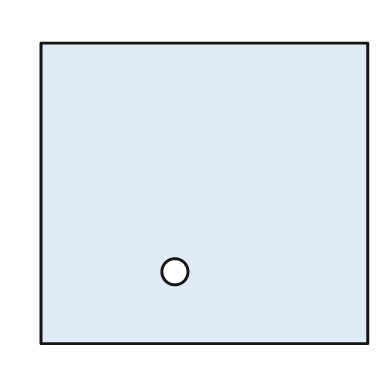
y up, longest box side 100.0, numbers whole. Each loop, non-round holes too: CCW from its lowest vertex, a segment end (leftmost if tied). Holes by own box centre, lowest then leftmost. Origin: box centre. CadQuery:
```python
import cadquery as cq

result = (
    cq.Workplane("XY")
    .moveTo(-50.0, -46.0)
    .lineTo(50.0, -46.0)
    .lineTo(50.0, 46.0)
    .lineTo(-50.0, 46.0)
    .close()
    .moveTo(-9.0, -24.0)
    .circle(4.0)
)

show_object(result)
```